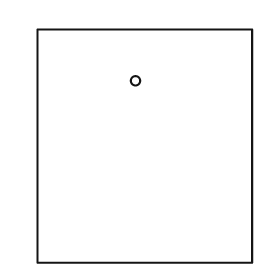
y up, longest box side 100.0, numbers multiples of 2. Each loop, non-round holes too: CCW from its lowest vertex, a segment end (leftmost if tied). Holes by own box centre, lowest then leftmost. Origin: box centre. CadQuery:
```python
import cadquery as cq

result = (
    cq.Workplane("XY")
    .moveTo(-46.0, -50.0)
    .lineTo(46.0, -50.0)
    .lineTo(46.0, 50.0)
    .lineTo(-46.0, 50.0)
    .close()
    .moveTo(-4.0, 28.0)
    .circle(2.0)
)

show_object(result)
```